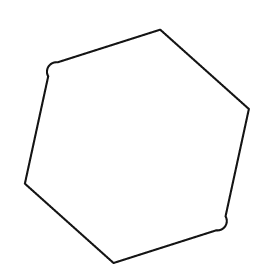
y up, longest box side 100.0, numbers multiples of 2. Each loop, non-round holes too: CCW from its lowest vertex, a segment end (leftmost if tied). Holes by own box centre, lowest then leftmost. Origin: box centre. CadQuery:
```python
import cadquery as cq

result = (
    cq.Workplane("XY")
    .moveTo(-10.0, -50.0)
    .lineTo(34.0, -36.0)
    .threePointArc((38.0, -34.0), (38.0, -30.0))
    .lineTo(48.0, 16.0)
    .lineTo(10.0, 50.0)
    .lineTo(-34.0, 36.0)
    .threePointArc((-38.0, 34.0), (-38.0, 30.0))
    .lineTo(-48.0, -16.0)
    .close()
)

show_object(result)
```